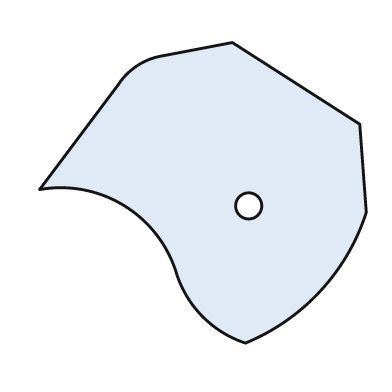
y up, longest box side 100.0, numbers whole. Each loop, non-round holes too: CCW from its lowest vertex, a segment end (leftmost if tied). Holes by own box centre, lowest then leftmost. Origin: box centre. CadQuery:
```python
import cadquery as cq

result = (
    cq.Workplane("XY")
    .moveTo(13.0, -46.0)
    .threePointArc((36.0, -30.0), (50.0, -6.0))
    .lineTo(48.0, 21.0)
    .lineTo(9.0, 46.0)
    .lineTo(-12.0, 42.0)
    .threePointArc((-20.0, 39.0), (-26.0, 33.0))
    .lineTo(-50.0, 1.0)
    .threePointArc((-24.0, -4.0), (-8.0, -25.0))
    .threePointArc((0.0, -38.0), (13.0, -46.0))
    .close()
    .moveTo(14.0, -4.0)
    .circle(4.0)
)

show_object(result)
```